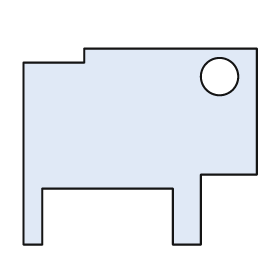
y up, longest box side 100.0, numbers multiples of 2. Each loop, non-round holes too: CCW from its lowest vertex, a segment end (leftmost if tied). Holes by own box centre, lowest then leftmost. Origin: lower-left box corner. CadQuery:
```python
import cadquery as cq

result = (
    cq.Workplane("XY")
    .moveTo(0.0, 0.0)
    .lineTo(8.0, 0.0)
    .lineTo(8.0, 24.0)
    .lineTo(64.0, 24.0)
    .lineTo(64.0, 0.0)
    .lineTo(76.0, 0.0)
    .lineTo(76.0, 30.0)
    .lineTo(100.0, 30.0)
    .lineTo(100.0, 84.0)
    .lineTo(26.0, 84.0)
    .lineTo(26.0, 78.0)
    .lineTo(0.0, 78.0)
    .close()
    .moveTo(84.0, 72.0)
    .circle(8.0)
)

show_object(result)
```